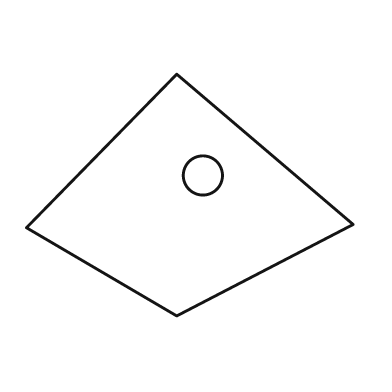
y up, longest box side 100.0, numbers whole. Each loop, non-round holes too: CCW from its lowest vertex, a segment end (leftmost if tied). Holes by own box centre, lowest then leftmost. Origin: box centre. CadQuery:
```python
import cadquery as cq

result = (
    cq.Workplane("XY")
    .moveTo(-4.0, -37.0)
    .lineTo(50.0, -9.0)
    .lineTo(-4.0, 37.0)
    .lineTo(-50.0, -10.0)
    .close()
    .moveTo(4.0, 6.0)
    .circle(6.0)
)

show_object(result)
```